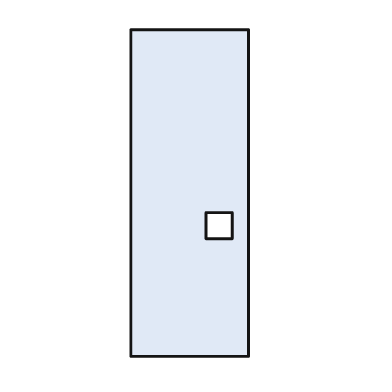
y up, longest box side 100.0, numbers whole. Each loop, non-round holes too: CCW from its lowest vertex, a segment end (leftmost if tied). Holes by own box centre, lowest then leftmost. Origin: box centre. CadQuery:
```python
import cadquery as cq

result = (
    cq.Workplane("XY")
    .moveTo(-18.0, -50.0)
    .lineTo(18.0, -50.0)
    .lineTo(18.0, 50.0)
    .lineTo(-18.0, 50.0)
    .close()
    .moveTo(5.0, -14.0)
    .lineTo(13.0, -14.0)
    .lineTo(13.0, -6.0)
    .lineTo(5.0, -6.0)
    .close()
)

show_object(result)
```